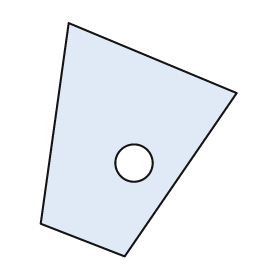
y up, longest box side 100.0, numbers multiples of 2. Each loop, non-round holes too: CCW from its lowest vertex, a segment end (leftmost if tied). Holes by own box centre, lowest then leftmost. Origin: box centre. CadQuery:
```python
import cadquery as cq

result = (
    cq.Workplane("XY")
    .moveTo(-6.0, -50.0)
    .lineTo(42.0, 20.0)
    .lineTo(-30.0, 50.0)
    .lineTo(-42.0, -36.0)
    .close()
    .moveTo(-2.0, -10.0)
    .circle(8.0)
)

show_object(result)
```